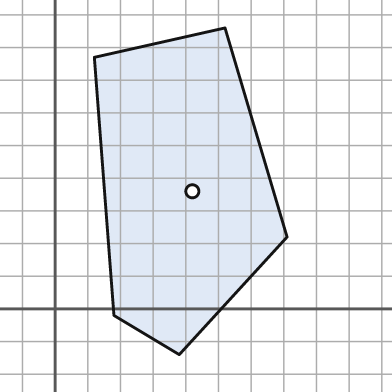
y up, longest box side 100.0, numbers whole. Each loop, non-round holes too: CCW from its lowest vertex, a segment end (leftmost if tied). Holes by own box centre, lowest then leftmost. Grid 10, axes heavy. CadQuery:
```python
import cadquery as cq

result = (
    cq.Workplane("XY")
    .moveTo(38.0, -14.0)
    .lineTo(71.0, 22.0)
    .lineTo(52.0, 86.0)
    .lineTo(12.0, 77.0)
    .lineTo(18.0, -2.0)
    .close()
    .moveTo(42.0, 36.0)
    .circle(2.0)
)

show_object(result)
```